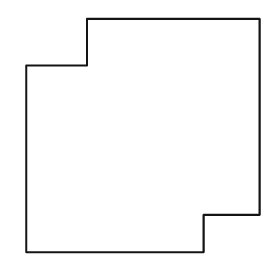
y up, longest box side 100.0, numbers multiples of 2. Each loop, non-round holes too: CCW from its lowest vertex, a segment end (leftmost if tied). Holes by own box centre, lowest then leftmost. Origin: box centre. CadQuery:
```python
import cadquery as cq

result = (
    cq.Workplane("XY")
    .moveTo(-50.0, -50.0)
    .lineTo(26.0, -50.0)
    .lineTo(26.0, -34.0)
    .lineTo(50.0, -34.0)
    .lineTo(50.0, 50.0)
    .lineTo(-24.0, 50.0)
    .lineTo(-24.0, 30.0)
    .lineTo(-50.0, 30.0)
    .close()
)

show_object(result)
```